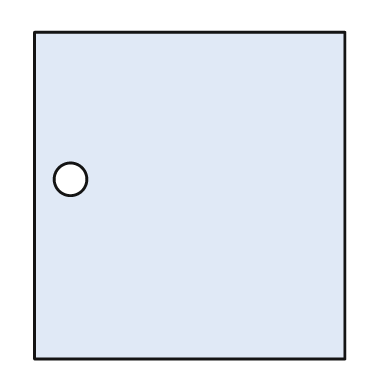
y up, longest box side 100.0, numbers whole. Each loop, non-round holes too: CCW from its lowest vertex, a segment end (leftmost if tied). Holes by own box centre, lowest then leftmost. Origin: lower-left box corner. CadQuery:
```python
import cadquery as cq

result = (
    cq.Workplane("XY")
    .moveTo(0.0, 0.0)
    .lineTo(95.0, 0.0)
    .lineTo(95.0, 100.0)
    .lineTo(0.0, 100.0)
    .close()
    .moveTo(11.0, 55.0)
    .circle(5.0)
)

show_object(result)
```